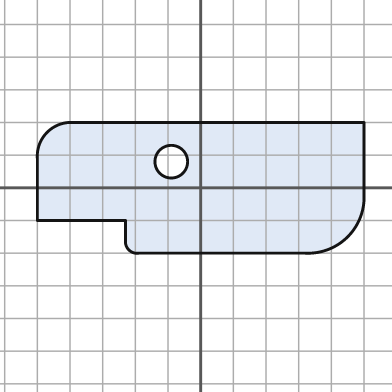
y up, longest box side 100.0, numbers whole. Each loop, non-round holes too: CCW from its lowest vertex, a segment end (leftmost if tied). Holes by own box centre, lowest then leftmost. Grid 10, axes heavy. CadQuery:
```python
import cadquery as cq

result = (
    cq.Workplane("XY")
    .moveTo(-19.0, -20.0)
    .lineTo(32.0, -20.0)
    .threePointArc((45.0, -15.0), (50.0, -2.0))
    .lineTo(50.0, 20.0)
    .lineTo(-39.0, 20.0)
    .threePointArc((-47.0, 17.0), (-50.0, 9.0))
    .lineTo(-50.0, -10.0)
    .lineTo(-23.0, -10.0)
    .lineTo(-23.0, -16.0)
    .threePointArc((-22.0, -19.0), (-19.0, -20.0))
    .close()
    .moveTo(-9.0, 8.0)
    .circle(5.0)
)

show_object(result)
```